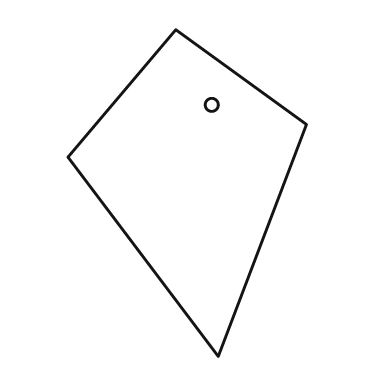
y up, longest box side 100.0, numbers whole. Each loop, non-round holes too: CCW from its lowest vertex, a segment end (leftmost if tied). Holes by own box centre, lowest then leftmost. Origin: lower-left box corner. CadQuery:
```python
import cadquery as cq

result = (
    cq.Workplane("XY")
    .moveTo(46.0, 0.0)
    .lineTo(73.0, 71.0)
    .lineTo(33.0, 100.0)
    .lineTo(0.0, 61.0)
    .close()
    .moveTo(44.0, 77.0)
    .circle(2.0)
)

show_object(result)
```